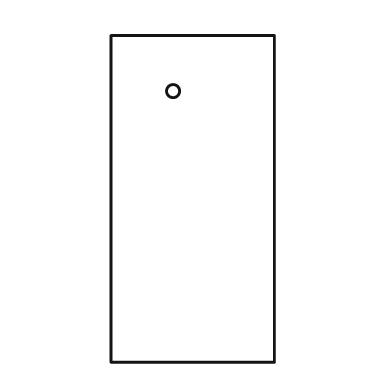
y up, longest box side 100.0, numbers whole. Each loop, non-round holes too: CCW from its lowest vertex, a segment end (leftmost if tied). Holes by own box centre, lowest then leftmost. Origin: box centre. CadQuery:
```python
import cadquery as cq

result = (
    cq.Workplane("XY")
    .moveTo(-25.0, -50.0)
    .lineTo(25.0, -50.0)
    .lineTo(25.0, 50.0)
    .lineTo(-25.0, 50.0)
    .close()
    .moveTo(-6.0, 33.0)
    .circle(2.0)
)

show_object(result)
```